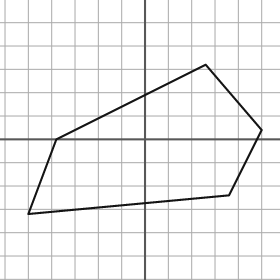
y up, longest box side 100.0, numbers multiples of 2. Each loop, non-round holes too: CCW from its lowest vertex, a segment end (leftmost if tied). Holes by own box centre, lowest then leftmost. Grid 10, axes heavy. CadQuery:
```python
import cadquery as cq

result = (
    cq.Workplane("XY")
    .moveTo(-50.0, -32.0)
    .lineTo(36.0, -24.0)
    .lineTo(50.0, 4.0)
    .lineTo(26.0, 32.0)
    .lineTo(-38.0, 0.0)
    .close()
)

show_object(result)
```